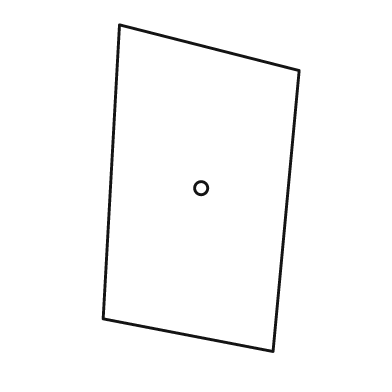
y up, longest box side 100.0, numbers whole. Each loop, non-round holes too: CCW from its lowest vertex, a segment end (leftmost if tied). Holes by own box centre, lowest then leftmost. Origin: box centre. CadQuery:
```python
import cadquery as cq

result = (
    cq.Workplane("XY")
    .moveTo(22.0, -50.0)
    .lineTo(30.0, 36.0)
    .lineTo(-25.0, 50.0)
    .lineTo(-30.0, -40.0)
    .close()
    .moveTo(0.0, 0.0)
    .circle(2.0)
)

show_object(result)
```